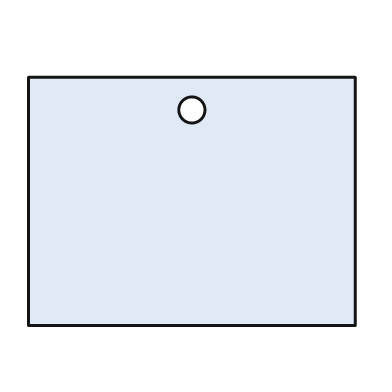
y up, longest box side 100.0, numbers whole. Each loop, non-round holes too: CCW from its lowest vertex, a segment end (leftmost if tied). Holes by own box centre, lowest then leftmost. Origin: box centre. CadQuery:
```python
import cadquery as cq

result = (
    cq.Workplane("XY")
    .moveTo(-50.0, -38.0)
    .lineTo(50.0, -38.0)
    .lineTo(50.0, 38.0)
    .lineTo(-50.0, 38.0)
    .close()
    .moveTo(0.0, 28.0)
    .circle(4.0)
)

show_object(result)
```